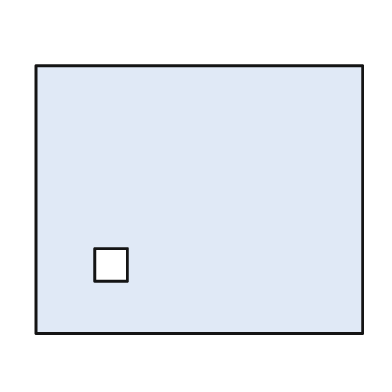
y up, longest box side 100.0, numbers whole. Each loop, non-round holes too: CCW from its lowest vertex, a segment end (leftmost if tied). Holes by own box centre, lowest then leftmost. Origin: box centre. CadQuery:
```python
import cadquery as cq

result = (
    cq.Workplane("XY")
    .moveTo(-50.0, -41.0)
    .lineTo(50.0, -41.0)
    .lineTo(50.0, 41.0)
    .lineTo(-50.0, 41.0)
    .close()
    .moveTo(-32.0, -25.0)
    .lineTo(-22.0, -25.0)
    .lineTo(-22.0, -15.0)
    .lineTo(-32.0, -15.0)
    .close()
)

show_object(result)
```